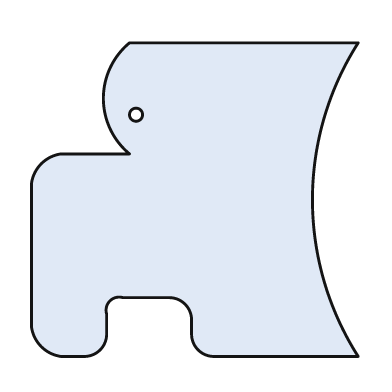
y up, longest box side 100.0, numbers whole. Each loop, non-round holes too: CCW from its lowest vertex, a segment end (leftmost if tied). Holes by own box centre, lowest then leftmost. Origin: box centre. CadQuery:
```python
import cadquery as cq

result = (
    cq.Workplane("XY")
    .moveTo(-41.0, -48.0)
    .lineTo(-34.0, -48.0)
    .threePointArc((-29.0, -46.0), (-27.0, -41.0))
    .lineTo(-27.0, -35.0)
    .threePointArc((-26.0, -31.0), (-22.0, -30.0))
    .lineTo(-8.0, -30.0)
    .threePointArc((-3.0, -32.0), (-1.0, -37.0))
    .lineTo(-1.0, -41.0)
    .threePointArc((1.0, -46.0), (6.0, -48.0))
    .lineTo(50.0, -48.0)
    .threePointArc((36.0, 0.0), (50.0, 48.0))
    .lineTo(-20.0, 48.0)
    .threePointArc((-28.0, 31.0), (-20.0, 14.0))
    .lineTo(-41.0, 14.0)
    .threePointArc((-47.0, 11.0), (-50.0, 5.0))
    .lineTo(-50.0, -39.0)
    .threePointArc((-47.0, -45.0), (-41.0, -48.0))
    .close()
    .moveTo(-18.0, 26.0)
    .circle(2.0)
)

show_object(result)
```